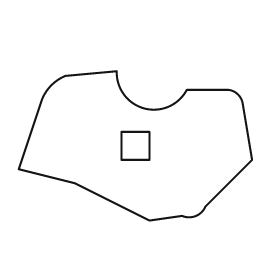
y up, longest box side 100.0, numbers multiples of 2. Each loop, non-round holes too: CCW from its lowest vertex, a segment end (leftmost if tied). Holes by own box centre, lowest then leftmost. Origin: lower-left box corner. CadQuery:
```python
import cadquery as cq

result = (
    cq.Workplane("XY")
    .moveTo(56.0, 0.0)
    .lineTo(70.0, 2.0)
    .threePointArc((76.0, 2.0), (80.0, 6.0))
    .lineTo(100.0, 26.0)
    .lineTo(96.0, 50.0)
    .threePointArc((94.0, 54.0), (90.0, 56.0))
    .lineTo(72.0, 56.0)
    .threePointArc((54.0, 48.0), (42.0, 64.0))
    .lineTo(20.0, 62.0)
    .threePointArc((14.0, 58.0), (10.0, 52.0))
    .lineTo(0.0, 22.0)
    .lineTo(24.0, 16.0)
    .close()
    .moveTo(44.0, 26.0)
    .lineTo(56.0, 26.0)
    .lineTo(56.0, 38.0)
    .lineTo(44.0, 38.0)
    .close()
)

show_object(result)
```